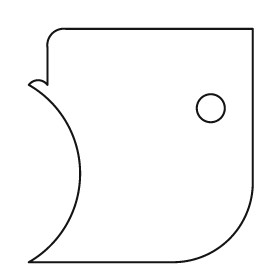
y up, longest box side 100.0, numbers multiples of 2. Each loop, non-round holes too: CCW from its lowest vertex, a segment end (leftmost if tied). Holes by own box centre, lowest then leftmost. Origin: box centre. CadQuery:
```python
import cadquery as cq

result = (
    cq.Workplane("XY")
    .moveTo(-48.0, -50.0)
    .lineTo(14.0, -50.0)
    .threePointArc((38.0, -40.0), (48.0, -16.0))
    .lineTo(48.0, 50.0)
    .lineTo(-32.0, 50.0)
    .threePointArc((-38.0, 48.0), (-40.0, 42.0))
    .lineTo(-40.0, 26.0)
    .threePointArc((-44.0, 28.0), (-48.0, 26.0))
    .threePointArc((-26.0, -12.0), (-48.0, -50.0))
    .close()
    .moveTo(30.0, 16.0)
    .circle(6.0)
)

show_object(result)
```